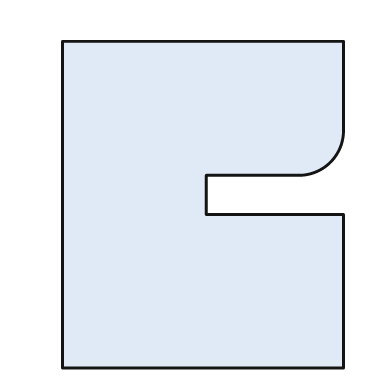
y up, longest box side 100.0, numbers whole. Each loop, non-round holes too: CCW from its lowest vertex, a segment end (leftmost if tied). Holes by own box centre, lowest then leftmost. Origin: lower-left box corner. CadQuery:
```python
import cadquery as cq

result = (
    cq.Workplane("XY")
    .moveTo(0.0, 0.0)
    .lineTo(86.0, 0.0)
    .lineTo(86.0, 47.0)
    .lineTo(44.0, 47.0)
    .lineTo(44.0, 59.0)
    .lineTo(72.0, 59.0)
    .threePointArc((82.0, 63.0), (86.0, 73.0))
    .lineTo(86.0, 100.0)
    .lineTo(0.0, 100.0)
    .close()
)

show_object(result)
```